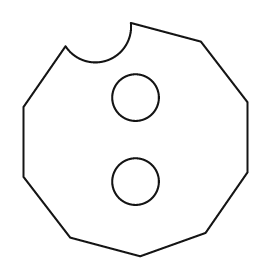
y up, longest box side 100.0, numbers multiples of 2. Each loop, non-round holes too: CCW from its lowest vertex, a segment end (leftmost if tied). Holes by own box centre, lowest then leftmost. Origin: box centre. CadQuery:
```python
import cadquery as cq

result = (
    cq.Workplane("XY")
    .moveTo(2.0, -50.0)
    .lineTo(30.0, -40.0)
    .lineTo(48.0, -14.0)
    .lineTo(48.0, 16.0)
    .lineTo(28.0, 42.0)
    .lineTo(-2.0, 50.0)
    .threePointArc((-12.0, 34.0), (-30.0, 40.0))
    .lineTo(-48.0, 14.0)
    .lineTo(-48.0, -16.0)
    .lineTo(-28.0, -42.0)
    .close()
    .moveTo(0.0, -18.0)
    .circle(10.0)
    .moveTo(0.0, 18.0)
    .circle(10.0)
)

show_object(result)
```